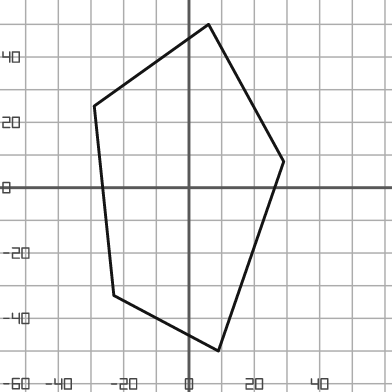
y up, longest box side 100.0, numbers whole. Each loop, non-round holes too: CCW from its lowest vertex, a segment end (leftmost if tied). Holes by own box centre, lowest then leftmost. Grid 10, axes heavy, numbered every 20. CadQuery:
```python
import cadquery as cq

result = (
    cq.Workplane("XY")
    .moveTo(9.0, -50.0)
    .lineTo(29.0, 8.0)
    .lineTo(6.0, 50.0)
    .lineTo(-29.0, 25.0)
    .lineTo(-23.0, -33.0)
    .close()
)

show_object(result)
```